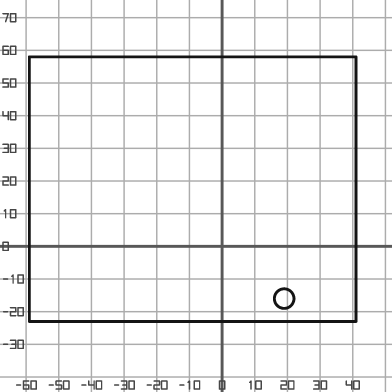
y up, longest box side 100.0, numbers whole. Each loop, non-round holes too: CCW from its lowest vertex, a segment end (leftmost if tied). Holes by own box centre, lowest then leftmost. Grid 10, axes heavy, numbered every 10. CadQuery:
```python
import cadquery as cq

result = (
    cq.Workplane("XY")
    .moveTo(-59.0, -23.0)
    .lineTo(41.0, -23.0)
    .lineTo(41.0, 58.0)
    .lineTo(-59.0, 58.0)
    .close()
    .moveTo(19.0, -16.0)
    .circle(3.0)
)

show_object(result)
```